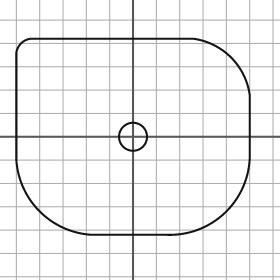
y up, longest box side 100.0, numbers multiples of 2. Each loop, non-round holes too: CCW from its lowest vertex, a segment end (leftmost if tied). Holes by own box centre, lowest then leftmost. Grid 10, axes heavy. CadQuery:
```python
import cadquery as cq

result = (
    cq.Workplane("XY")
    .moveTo(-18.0, -42.0)
    .lineTo(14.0, -42.0)
    .threePointArc((40.0, -32.0), (50.0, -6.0))
    .lineTo(50.0, 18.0)
    .threePointArc((42.0, 34.0), (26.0, 42.0))
    .lineTo(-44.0, 42.0)
    .threePointArc((-48.0, 40.0), (-50.0, 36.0))
    .lineTo(-50.0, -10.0)
    .threePointArc((-40.0, -32.0), (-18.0, -42.0))
    .close()
    .moveTo(0.0, 0.0)
    .circle(6.0)
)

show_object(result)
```